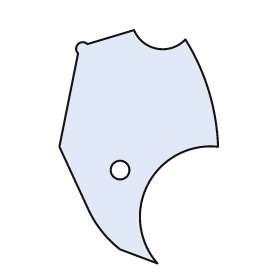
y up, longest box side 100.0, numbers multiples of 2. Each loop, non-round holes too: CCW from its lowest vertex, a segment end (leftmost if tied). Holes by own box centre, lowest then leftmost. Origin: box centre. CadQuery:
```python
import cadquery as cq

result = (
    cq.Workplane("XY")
    .moveTo(8.0, -50.0)
    .threePointArc((4.0, -16.0), (34.0, 0.0))
    .threePointArc((30.0, 24.0), (20.0, 46.0))
    .threePointArc((8.0, 42.0), (-2.0, 50.0))
    .lineTo(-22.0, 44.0)
    .threePointArc((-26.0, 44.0), (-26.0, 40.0))
    .lineTo(-34.0, 0.0)
    .lineTo(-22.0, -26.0)
    .threePointArc((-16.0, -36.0), (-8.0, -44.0))
    .close()
    .moveTo(-8.0, -10.0)
    .circle(4.0)
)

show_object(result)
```